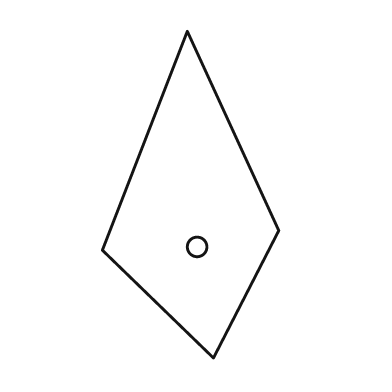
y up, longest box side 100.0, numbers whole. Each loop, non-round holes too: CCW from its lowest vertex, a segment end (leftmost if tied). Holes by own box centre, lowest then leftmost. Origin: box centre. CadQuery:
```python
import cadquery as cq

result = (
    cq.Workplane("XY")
    .moveTo(7.0, -50.0)
    .lineTo(27.0, -11.0)
    .lineTo(-1.0, 50.0)
    .lineTo(-27.0, -17.0)
    .close()
    .moveTo(2.0, -16.0)
    .circle(3.0)
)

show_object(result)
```